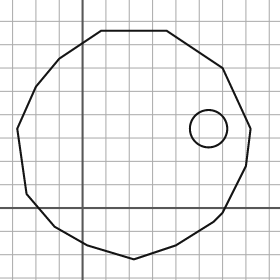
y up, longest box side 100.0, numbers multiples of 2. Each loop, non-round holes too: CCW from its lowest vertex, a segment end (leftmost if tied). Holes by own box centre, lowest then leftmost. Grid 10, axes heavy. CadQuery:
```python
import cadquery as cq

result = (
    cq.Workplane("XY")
    .moveTo(22.0, -22.0)
    .lineTo(40.0, -16.0)
    .lineTo(56.0, -6.0)
    .lineTo(60.0, -2.0)
    .lineTo(70.0, 18.0)
    .lineTo(72.0, 34.0)
    .lineTo(60.0, 60.0)
    .lineTo(36.0, 76.0)
    .lineTo(8.0, 76.0)
    .lineTo(-10.0, 64.0)
    .lineTo(-20.0, 52.0)
    .lineTo(-28.0, 34.0)
    .lineTo(-24.0, 6.0)
    .lineTo(-12.0, -8.0)
    .lineTo(2.0, -16.0)
    .close()
    .moveTo(54.0, 34.0)
    .circle(8.0)
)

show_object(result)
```